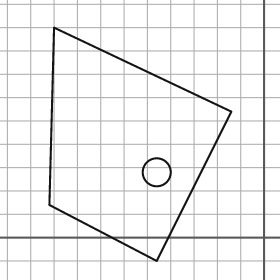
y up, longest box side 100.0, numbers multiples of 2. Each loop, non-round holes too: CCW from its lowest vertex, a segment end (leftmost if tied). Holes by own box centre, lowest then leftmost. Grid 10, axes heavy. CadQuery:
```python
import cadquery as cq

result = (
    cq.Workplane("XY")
    .moveTo(-46.0, -10.0)
    .lineTo(-14.0, 54.0)
    .lineTo(-90.0, 90.0)
    .lineTo(-92.0, 14.0)
    .close()
    .moveTo(-46.0, 28.0)
    .circle(6.0)
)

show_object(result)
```